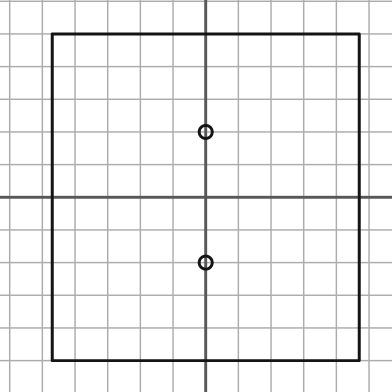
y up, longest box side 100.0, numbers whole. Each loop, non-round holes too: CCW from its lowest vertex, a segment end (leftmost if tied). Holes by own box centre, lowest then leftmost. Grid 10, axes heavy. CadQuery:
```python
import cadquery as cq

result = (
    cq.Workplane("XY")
    .moveTo(-47.0, -50.0)
    .lineTo(47.0, -50.0)
    .lineTo(47.0, 50.0)
    .lineTo(-47.0, 50.0)
    .close()
    .moveTo(0.0, -20.0)
    .circle(2.0)
    .moveTo(0.0, 20.0)
    .circle(2.0)
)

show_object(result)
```